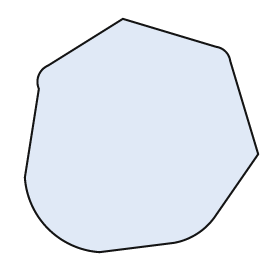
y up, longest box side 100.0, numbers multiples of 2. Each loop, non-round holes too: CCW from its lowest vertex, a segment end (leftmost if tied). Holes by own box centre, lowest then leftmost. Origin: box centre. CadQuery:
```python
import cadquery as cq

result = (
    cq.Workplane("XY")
    .moveTo(-18.0, -50.0)
    .lineTo(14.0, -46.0)
    .threePointArc((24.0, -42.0), (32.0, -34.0))
    .lineTo(50.0, -8.0)
    .lineTo(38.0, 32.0)
    .threePointArc((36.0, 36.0), (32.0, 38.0))
    .lineTo(-8.0, 50.0)
    .lineTo(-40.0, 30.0)
    .threePointArc((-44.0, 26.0), (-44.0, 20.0))
    .lineTo(-50.0, -18.0)
    .threePointArc((-40.0, -40.0), (-18.0, -50.0))
    .close()
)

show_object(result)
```